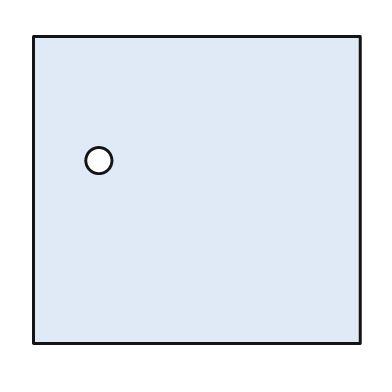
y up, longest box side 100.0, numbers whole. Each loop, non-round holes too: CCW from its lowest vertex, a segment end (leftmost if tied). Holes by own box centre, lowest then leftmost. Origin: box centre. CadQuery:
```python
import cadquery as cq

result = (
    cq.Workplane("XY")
    .moveTo(-50.0, -47.0)
    .lineTo(50.0, -47.0)
    .lineTo(50.0, 47.0)
    .lineTo(-50.0, 47.0)
    .close()
    .moveTo(-30.0, 9.0)
    .circle(4.0)
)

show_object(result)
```